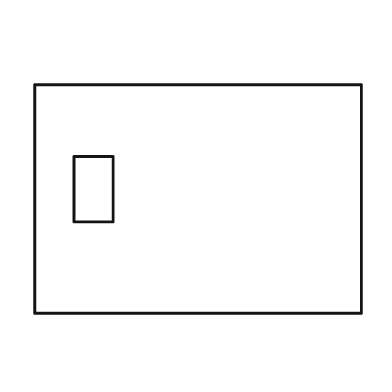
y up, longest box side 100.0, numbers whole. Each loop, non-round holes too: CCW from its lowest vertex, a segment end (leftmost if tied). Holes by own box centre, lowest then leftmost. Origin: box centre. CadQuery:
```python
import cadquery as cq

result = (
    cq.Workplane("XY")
    .moveTo(-50.0, -35.0)
    .lineTo(50.0, -35.0)
    .lineTo(50.0, 35.0)
    .lineTo(-50.0, 35.0)
    .close()
    .moveTo(-38.0, -7.0)
    .lineTo(-26.0, -7.0)
    .lineTo(-26.0, 13.0)
    .lineTo(-38.0, 13.0)
    .close()
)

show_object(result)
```